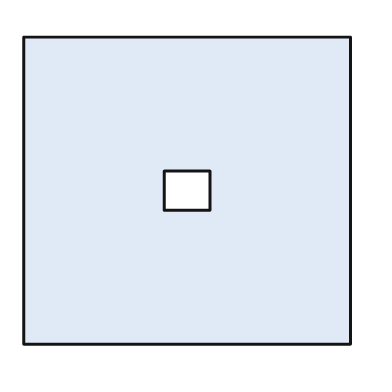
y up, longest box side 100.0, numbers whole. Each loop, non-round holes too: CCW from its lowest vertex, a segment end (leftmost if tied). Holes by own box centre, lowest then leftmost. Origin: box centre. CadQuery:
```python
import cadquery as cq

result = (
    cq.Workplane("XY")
    .moveTo(-50.0, -47.0)
    .lineTo(50.0, -47.0)
    .lineTo(50.0, 47.0)
    .lineTo(-50.0, 47.0)
    .close()
    .moveTo(-7.0, -6.0)
    .lineTo(7.0, -6.0)
    .lineTo(7.0, 6.0)
    .lineTo(-7.0, 6.0)
    .close()
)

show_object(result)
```